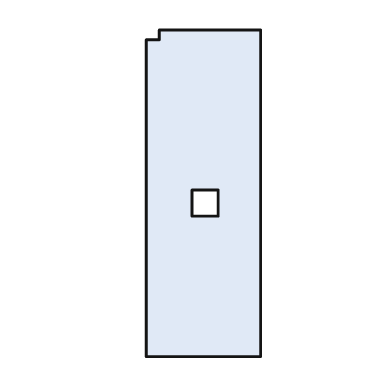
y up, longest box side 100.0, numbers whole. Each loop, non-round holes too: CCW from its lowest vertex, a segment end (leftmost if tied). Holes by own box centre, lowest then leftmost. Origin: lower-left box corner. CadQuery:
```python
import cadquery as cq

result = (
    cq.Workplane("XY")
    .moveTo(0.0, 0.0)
    .lineTo(35.0, 0.0)
    .lineTo(35.0, 100.0)
    .lineTo(4.0, 100.0)
    .lineTo(4.0, 97.0)
    .lineTo(0.0, 97.0)
    .close()
    .moveTo(14.0, 43.0)
    .lineTo(22.0, 43.0)
    .lineTo(22.0, 51.0)
    .lineTo(14.0, 51.0)
    .close()
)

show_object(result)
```